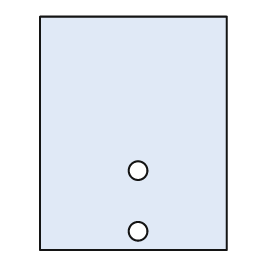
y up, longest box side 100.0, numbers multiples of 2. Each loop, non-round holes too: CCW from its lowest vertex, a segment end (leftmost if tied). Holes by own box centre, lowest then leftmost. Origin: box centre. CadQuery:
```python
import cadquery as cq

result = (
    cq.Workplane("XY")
    .moveTo(-40.0, -50.0)
    .lineTo(40.0, -50.0)
    .lineTo(40.0, 50.0)
    .lineTo(-40.0, 50.0)
    .close()
    .moveTo(2.0, -42.0)
    .circle(4.0)
    .moveTo(2.0, -16.0)
    .circle(4.0)
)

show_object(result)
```